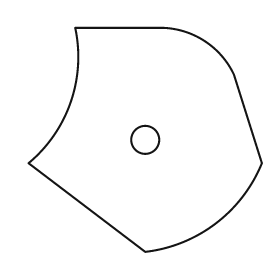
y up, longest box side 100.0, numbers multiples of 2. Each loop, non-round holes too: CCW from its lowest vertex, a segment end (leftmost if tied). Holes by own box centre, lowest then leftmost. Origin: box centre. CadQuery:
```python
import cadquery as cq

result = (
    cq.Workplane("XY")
    .moveTo(0.0, -48.0)
    .threePointArc((30.0, -36.0), (50.0, -10.0))
    .lineTo(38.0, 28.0)
    .threePointArc((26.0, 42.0), (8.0, 48.0))
    .lineTo(-30.0, 48.0)
    .threePointArc((-32.0, 16.0), (-50.0, -10.0))
    .close()
    .moveTo(0.0, 0.0)
    .circle(6.0)
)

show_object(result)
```